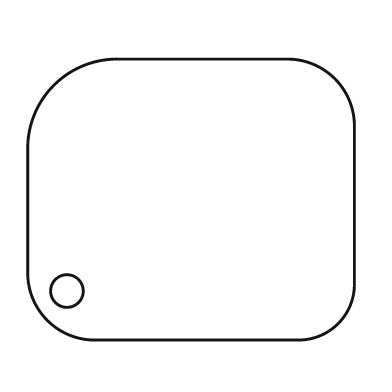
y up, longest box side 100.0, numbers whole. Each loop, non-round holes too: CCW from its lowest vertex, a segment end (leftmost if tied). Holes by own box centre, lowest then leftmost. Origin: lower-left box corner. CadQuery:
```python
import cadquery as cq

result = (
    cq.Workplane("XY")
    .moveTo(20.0, 0.0)
    .lineTo(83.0, 0.0)
    .threePointArc((95.0, 5.0), (100.0, 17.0))
    .lineTo(100.0, 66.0)
    .threePointArc((94.0, 80.0), (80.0, 86.0))
    .lineTo(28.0, 86.0)
    .threePointArc((8.0, 78.0), (0.0, 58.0))
    .lineTo(0.0, 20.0)
    .threePointArc((6.0, 6.0), (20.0, 0.0))
    .close()
    .moveTo(12.0, 15.0)
    .circle(5.0)
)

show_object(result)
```